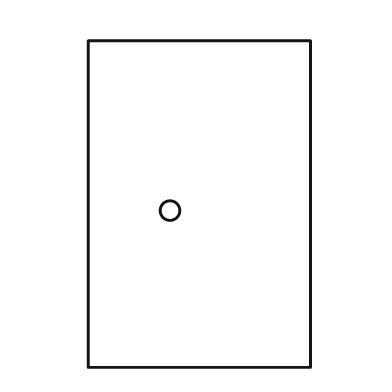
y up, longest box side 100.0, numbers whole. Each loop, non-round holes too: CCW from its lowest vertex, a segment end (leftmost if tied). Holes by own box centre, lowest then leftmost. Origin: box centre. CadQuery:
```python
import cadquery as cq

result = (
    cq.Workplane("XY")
    .moveTo(-34.0, -50.0)
    .lineTo(34.0, -50.0)
    .lineTo(34.0, 50.0)
    .lineTo(-34.0, 50.0)
    .close()
    .moveTo(-9.0, -2.0)
    .circle(3.0)
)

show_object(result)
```